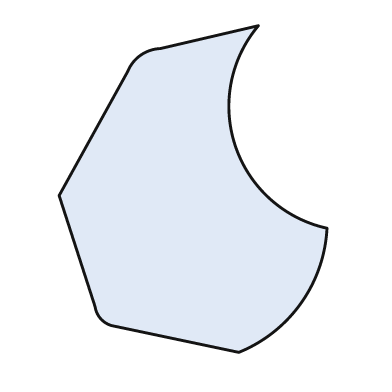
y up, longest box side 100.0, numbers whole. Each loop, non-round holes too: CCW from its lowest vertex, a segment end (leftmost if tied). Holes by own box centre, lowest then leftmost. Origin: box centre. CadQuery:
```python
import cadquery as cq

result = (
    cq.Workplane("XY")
    .moveTo(14.0, -50.0)
    .threePointArc((33.0, -35.0), (41.0, -12.0))
    .threePointArc((13.0, 13.0), (20.0, 50.0))
    .lineTo(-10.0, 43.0)
    .threePointArc((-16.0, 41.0), (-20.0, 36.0))
    .lineTo(-41.0, -2.0)
    .lineTo(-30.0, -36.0)
    .threePointArc((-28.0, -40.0), (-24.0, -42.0))
    .close()
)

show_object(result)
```